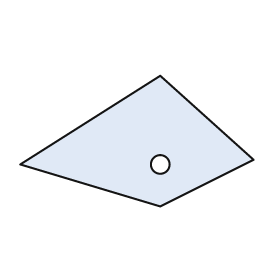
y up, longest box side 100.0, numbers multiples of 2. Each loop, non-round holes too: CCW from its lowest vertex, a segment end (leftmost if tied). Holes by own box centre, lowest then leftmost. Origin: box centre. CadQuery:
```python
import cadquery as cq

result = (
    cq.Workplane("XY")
    .moveTo(10.0, -28.0)
    .lineTo(50.0, -8.0)
    .lineTo(10.0, 28.0)
    .lineTo(-50.0, -10.0)
    .close()
    .moveTo(10.0, -10.0)
    .circle(4.0)
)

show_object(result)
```